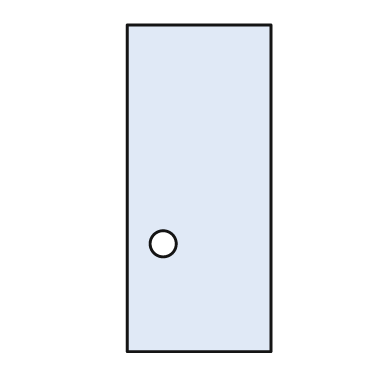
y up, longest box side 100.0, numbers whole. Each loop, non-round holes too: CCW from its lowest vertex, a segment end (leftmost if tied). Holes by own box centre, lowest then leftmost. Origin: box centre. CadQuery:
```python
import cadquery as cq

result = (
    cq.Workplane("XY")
    .moveTo(-22.0, -50.0)
    .lineTo(22.0, -50.0)
    .lineTo(22.0, 50.0)
    .lineTo(-22.0, 50.0)
    .close()
    .moveTo(-11.0, -17.0)
    .circle(4.0)
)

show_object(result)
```